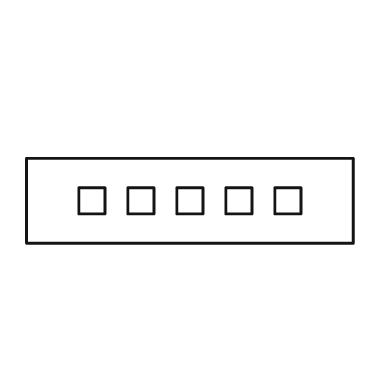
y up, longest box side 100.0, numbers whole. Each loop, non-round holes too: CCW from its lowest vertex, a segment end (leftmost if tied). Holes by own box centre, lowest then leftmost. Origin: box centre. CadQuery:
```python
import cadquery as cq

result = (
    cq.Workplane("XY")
    .moveTo(-50.0, -13.0)
    .lineTo(50.0, -13.0)
    .lineTo(50.0, 13.0)
    .lineTo(-50.0, 13.0)
    .close()
    .moveTo(-34.0, -4.0)
    .lineTo(-26.0, -4.0)
    .lineTo(-26.0, 4.0)
    .lineTo(-34.0, 4.0)
    .close()
    .moveTo(-19.0, -4.0)
    .lineTo(-11.0, -4.0)
    .lineTo(-11.0, 4.0)
    .lineTo(-19.0, 4.0)
    .close()
    .moveTo(-4.0, -4.0)
    .lineTo(4.0, -4.0)
    .lineTo(4.0, 4.0)
    .lineTo(-4.0, 4.0)
    .close()
    .moveTo(11.0, -4.0)
    .lineTo(19.0, -4.0)
    .lineTo(19.0, 4.0)
    .lineTo(11.0, 4.0)
    .close()
    .moveTo(26.0, -4.0)
    .lineTo(34.0, -4.0)
    .lineTo(34.0, 4.0)
    .lineTo(26.0, 4.0)
    .close()
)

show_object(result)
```